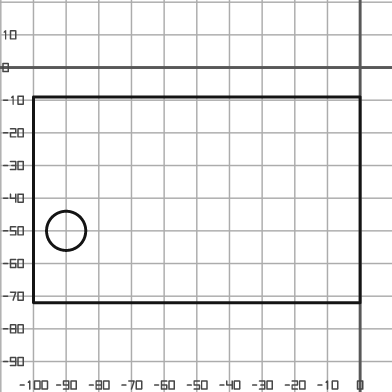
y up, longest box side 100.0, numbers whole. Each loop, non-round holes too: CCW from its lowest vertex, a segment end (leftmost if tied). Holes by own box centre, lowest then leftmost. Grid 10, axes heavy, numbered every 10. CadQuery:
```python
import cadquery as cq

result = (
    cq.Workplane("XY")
    .moveTo(-100.0, -72.0)
    .lineTo(0.0, -72.0)
    .lineTo(0.0, -9.0)
    .lineTo(-100.0, -9.0)
    .close()
    .moveTo(-90.0, -50.0)
    .circle(6.0)
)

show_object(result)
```